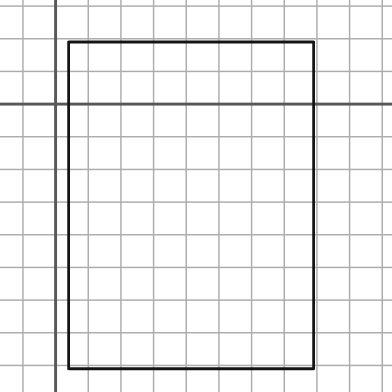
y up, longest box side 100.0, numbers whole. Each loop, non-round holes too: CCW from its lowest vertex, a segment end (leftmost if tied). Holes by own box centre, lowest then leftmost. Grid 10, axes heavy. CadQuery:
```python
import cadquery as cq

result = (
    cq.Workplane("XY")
    .moveTo(4.0, -81.0)
    .lineTo(79.0, -81.0)
    .lineTo(79.0, 19.0)
    .lineTo(4.0, 19.0)
    .close()
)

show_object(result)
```